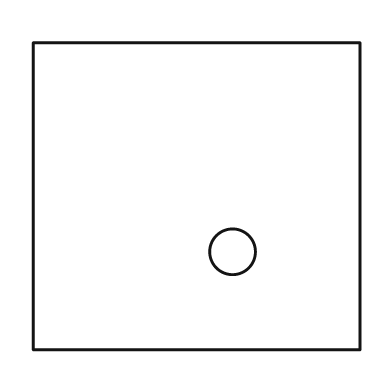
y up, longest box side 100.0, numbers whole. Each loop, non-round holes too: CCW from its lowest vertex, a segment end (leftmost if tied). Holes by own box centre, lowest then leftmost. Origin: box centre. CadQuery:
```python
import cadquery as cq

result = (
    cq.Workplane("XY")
    .moveTo(-50.0, -47.0)
    .lineTo(50.0, -47.0)
    .lineTo(50.0, 47.0)
    .lineTo(-50.0, 47.0)
    .close()
    .moveTo(11.0, -17.0)
    .circle(7.0)
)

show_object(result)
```